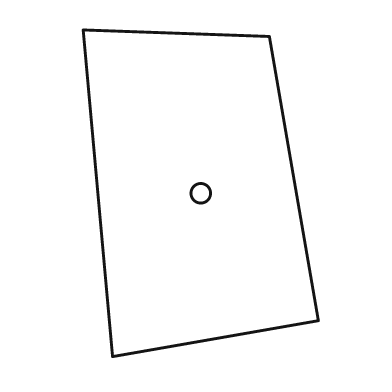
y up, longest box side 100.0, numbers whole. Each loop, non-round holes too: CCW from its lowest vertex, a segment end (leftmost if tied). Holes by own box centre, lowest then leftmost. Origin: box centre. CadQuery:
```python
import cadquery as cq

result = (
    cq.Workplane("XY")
    .moveTo(-27.0, -50.0)
    .lineTo(36.0, -39.0)
    .lineTo(21.0, 48.0)
    .lineTo(-36.0, 50.0)
    .close()
    .moveTo(0.0, 0.0)
    .circle(3.0)
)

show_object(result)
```